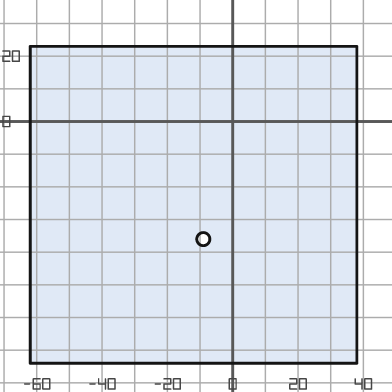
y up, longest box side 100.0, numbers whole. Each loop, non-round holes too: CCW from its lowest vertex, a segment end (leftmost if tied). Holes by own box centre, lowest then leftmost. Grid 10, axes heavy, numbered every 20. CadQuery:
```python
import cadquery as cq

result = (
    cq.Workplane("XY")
    .moveTo(-62.0, -74.0)
    .lineTo(38.0, -74.0)
    .lineTo(38.0, 23.0)
    .lineTo(-62.0, 23.0)
    .close()
    .moveTo(-9.0, -36.0)
    .circle(2.0)
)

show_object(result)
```